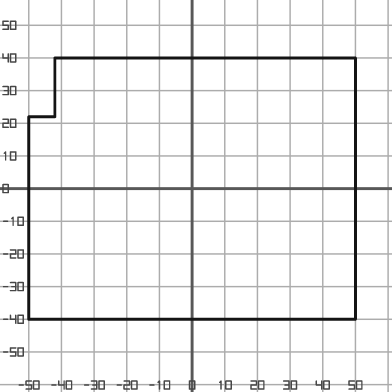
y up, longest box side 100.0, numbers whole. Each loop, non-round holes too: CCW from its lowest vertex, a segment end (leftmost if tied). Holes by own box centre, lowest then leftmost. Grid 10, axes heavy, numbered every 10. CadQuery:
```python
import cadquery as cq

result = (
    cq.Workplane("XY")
    .moveTo(-50.0, -40.0)
    .lineTo(50.0, -40.0)
    .lineTo(50.0, 40.0)
    .lineTo(-42.0, 40.0)
    .lineTo(-42.0, 22.0)
    .lineTo(-50.0, 22.0)
    .close()
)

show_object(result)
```